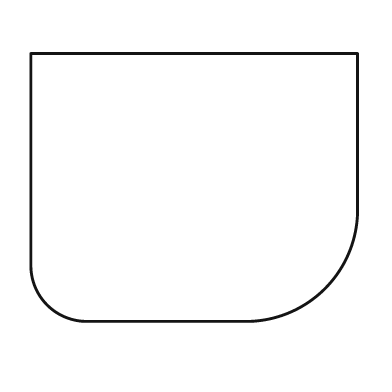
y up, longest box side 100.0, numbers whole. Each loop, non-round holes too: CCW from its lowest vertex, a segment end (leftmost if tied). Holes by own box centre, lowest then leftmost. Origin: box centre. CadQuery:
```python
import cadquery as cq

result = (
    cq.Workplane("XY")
    .moveTo(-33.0, -41.0)
    .lineTo(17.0, -41.0)
    .threePointArc((40.0, -31.0), (50.0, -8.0))
    .lineTo(50.0, 41.0)
    .lineTo(-50.0, 41.0)
    .lineTo(-50.0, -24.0)
    .threePointArc((-45.0, -36.0), (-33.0, -41.0))
    .close()
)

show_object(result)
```